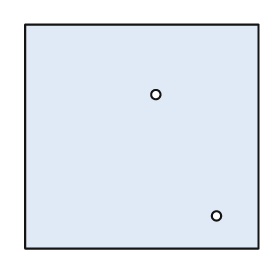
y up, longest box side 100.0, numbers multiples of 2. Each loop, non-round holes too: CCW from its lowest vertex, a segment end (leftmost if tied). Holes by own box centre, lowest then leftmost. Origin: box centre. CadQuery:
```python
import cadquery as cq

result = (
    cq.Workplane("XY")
    .moveTo(-50.0, -48.0)
    .lineTo(50.0, -48.0)
    .lineTo(50.0, 48.0)
    .lineTo(-50.0, 48.0)
    .close()
    .moveTo(32.0, -34.0)
    .circle(2.0)
    .moveTo(6.0, 18.0)
    .circle(2.0)
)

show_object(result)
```